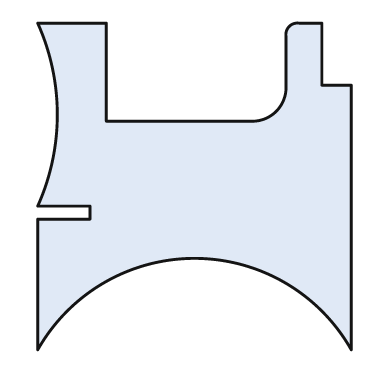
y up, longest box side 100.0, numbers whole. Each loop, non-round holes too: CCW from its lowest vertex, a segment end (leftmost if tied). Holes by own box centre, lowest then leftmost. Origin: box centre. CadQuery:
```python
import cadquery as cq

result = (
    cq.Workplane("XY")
    .moveTo(-48.0, -50.0)
    .threePointArc((0.0, -22.0), (48.0, -50.0))
    .lineTo(48.0, 31.0)
    .lineTo(39.0, 31.0)
    .lineTo(39.0, 50.0)
    .lineTo(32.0, 50.0)
    .threePointArc((29.0, 49.0), (28.0, 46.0))
    .lineTo(28.0, 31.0)
    .threePointArc((25.0, 23.0), (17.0, 20.0))
    .lineTo(-27.0, 20.0)
    .lineTo(-27.0, 50.0)
    .lineTo(-48.0, 50.0)
    .threePointArc((-42.0, 22.0), (-48.0, -6.0))
    .lineTo(-32.0, -6.0)
    .lineTo(-32.0, -10.0)
    .lineTo(-48.0, -10.0)
    .close()
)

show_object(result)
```